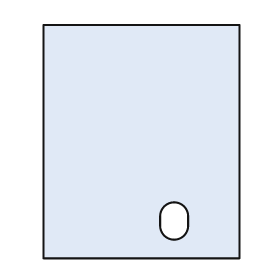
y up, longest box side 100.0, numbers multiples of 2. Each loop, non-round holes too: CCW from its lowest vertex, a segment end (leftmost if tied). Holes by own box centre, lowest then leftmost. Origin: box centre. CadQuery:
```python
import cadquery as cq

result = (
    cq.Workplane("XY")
    .moveTo(-42.0, -50.0)
    .lineTo(42.0, -50.0)
    .lineTo(42.0, 50.0)
    .lineTo(-42.0, 50.0)
    .close()
    .moveTo(8.0, -36.0)
    .threePointArc((14.0, -42.0), (20.0, -36.0))
    .lineTo(20.0, -32.0)
    .threePointArc((14.0, -26.0), (8.0, -32.0))
    .close()
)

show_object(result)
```